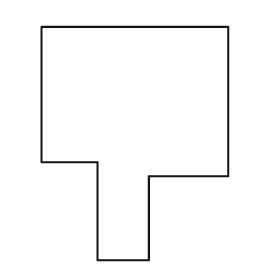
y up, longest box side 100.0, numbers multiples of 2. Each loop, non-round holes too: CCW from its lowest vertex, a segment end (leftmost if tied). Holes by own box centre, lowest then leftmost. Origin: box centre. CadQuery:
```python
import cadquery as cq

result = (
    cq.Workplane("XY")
    .moveTo(-16.0, -50.0)
    .lineTo(6.0, -50.0)
    .lineTo(6.0, -14.0)
    .lineTo(40.0, -14.0)
    .lineTo(40.0, 50.0)
    .lineTo(-40.0, 50.0)
    .lineTo(-40.0, -8.0)
    .lineTo(-16.0, -8.0)
    .close()
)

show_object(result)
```